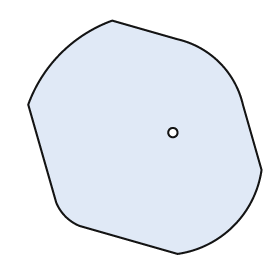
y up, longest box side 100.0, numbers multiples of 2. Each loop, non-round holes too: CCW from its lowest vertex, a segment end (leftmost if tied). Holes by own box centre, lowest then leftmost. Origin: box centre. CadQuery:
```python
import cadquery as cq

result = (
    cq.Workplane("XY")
    .moveTo(14.0, -50.0)
    .threePointArc((38.0, -38.0), (50.0, -14.0))
    .lineTo(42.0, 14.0)
    .threePointArc((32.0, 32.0), (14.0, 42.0))
    .lineTo(-14.0, 50.0)
    .threePointArc((-36.0, 36.0), (-50.0, 14.0))
    .lineTo(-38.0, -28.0)
    .threePointArc((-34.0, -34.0), (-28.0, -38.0))
    .close()
    .moveTo(12.0, 2.0)
    .circle(2.0)
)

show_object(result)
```